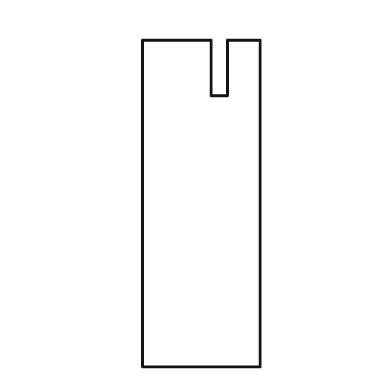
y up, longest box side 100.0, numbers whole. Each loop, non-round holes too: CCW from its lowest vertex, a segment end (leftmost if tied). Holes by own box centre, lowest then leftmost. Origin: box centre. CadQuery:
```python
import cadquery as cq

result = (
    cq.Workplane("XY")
    .moveTo(-18.0, -50.0)
    .lineTo(18.0, -50.0)
    .lineTo(18.0, 50.0)
    .lineTo(8.0, 50.0)
    .lineTo(8.0, 33.0)
    .lineTo(3.0, 33.0)
    .lineTo(3.0, 50.0)
    .lineTo(-18.0, 50.0)
    .close()
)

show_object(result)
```